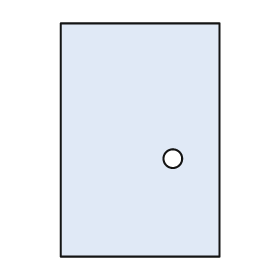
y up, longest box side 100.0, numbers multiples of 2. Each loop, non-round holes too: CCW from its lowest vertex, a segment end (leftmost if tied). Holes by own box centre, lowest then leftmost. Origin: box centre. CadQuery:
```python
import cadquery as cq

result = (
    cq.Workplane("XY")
    .moveTo(-34.0, -50.0)
    .lineTo(34.0, -50.0)
    .lineTo(34.0, 50.0)
    .lineTo(-34.0, 50.0)
    .close()
    .moveTo(14.0, -8.0)
    .circle(4.0)
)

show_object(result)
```